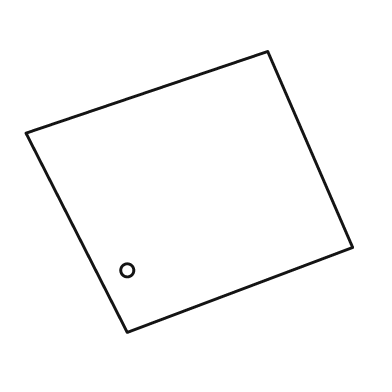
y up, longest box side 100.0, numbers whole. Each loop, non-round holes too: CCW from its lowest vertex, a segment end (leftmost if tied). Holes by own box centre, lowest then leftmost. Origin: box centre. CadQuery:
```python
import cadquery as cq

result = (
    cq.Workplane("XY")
    .moveTo(-19.0, -43.0)
    .lineTo(50.0, -17.0)
    .lineTo(24.0, 43.0)
    .lineTo(-50.0, 18.0)
    .close()
    .moveTo(-19.0, -24.0)
    .circle(2.0)
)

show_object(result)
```